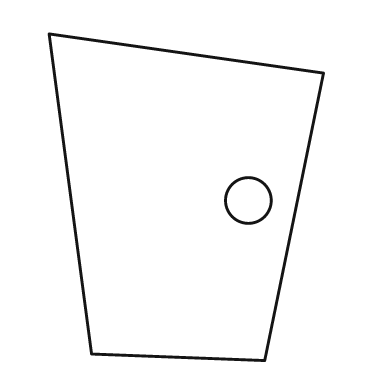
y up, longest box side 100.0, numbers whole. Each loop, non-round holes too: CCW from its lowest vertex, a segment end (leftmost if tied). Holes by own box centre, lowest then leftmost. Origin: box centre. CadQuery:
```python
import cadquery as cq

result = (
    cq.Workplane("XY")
    .moveTo(24.0, -50.0)
    .lineTo(42.0, 38.0)
    .lineTo(-42.0, 50.0)
    .lineTo(-29.0, -48.0)
    .close()
    .moveTo(19.0, -1.0)
    .circle(7.0)
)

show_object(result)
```